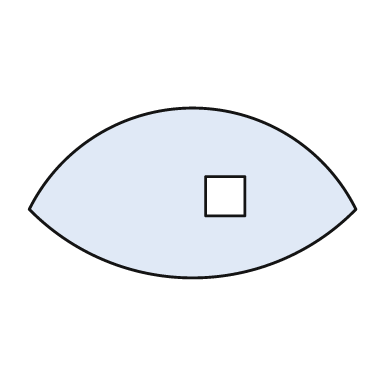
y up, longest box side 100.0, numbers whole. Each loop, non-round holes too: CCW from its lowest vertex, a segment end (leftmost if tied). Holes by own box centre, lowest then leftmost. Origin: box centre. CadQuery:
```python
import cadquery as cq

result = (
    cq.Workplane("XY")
    .moveTo(-50.0, -5.0)
    .threePointArc((0.0, -26.0), (50.0, -5.0))
    .threePointArc((0.0, 26.0), (-50.0, -5.0))
    .close()
    .moveTo(4.0, -7.0)
    .lineTo(16.0, -7.0)
    .lineTo(16.0, 5.0)
    .lineTo(4.0, 5.0)
    .close()
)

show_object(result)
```